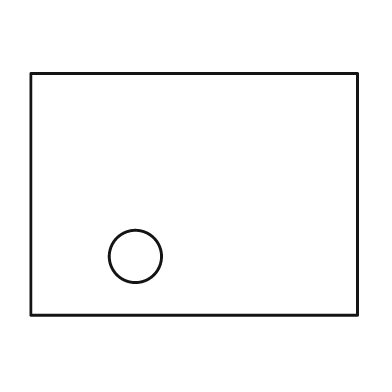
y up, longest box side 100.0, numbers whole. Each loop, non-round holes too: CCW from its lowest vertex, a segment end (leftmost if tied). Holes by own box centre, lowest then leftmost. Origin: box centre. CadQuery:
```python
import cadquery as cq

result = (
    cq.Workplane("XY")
    .moveTo(-50.0, -37.0)
    .lineTo(50.0, -37.0)
    .lineTo(50.0, 37.0)
    .lineTo(-50.0, 37.0)
    .close()
    .moveTo(-18.0, -19.0)
    .circle(8.0)
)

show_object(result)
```